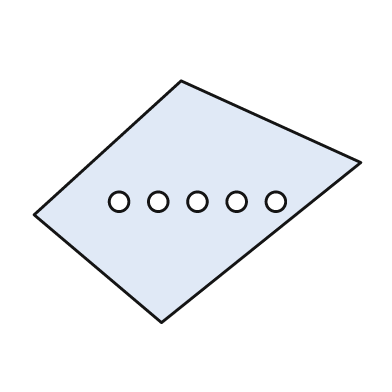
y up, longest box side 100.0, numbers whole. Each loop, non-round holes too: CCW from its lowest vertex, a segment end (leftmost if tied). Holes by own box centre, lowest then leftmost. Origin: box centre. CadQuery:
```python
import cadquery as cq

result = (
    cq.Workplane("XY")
    .moveTo(-11.0, -37.0)
    .lineTo(50.0, 12.0)
    .lineTo(-5.0, 37.0)
    .lineTo(-50.0, -4.0)
    .close()
    .moveTo(-24.0, 0.0)
    .circle(3.0)
    .moveTo(-12.0, 0.0)
    .circle(3.0)
    .moveTo(0.0, 0.0)
    .circle(3.0)
    .moveTo(12.0, 0.0)
    .circle(3.0)
    .moveTo(24.0, 0.0)
    .circle(3.0)
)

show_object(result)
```